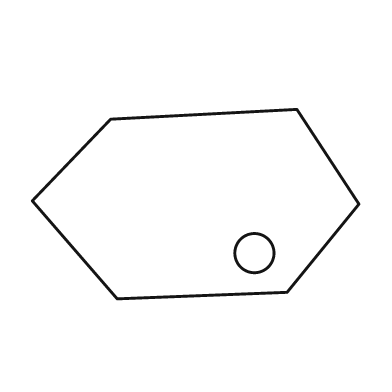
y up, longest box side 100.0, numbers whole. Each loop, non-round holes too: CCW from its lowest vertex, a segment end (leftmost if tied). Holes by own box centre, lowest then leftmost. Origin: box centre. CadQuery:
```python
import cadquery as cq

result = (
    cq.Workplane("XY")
    .moveTo(-24.0, -29.0)
    .lineTo(28.0, -27.0)
    .lineTo(50.0, 0.0)
    .lineTo(31.0, 29.0)
    .lineTo(-26.0, 26.0)
    .lineTo(-50.0, 1.0)
    .close()
    .moveTo(18.0, -15.0)
    .circle(6.0)
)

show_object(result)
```